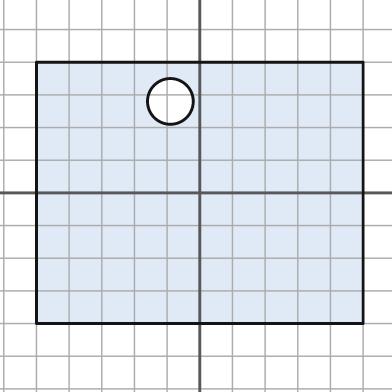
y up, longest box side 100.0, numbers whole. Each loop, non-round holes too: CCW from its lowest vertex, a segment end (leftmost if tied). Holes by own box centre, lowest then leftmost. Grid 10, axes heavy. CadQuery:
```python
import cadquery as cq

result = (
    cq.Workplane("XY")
    .moveTo(-50.0, -40.0)
    .lineTo(50.0, -40.0)
    .lineTo(50.0, 40.0)
    .lineTo(-50.0, 40.0)
    .close()
    .moveTo(-9.0, 28.0)
    .circle(7.0)
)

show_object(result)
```